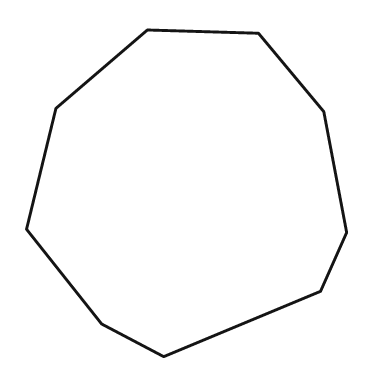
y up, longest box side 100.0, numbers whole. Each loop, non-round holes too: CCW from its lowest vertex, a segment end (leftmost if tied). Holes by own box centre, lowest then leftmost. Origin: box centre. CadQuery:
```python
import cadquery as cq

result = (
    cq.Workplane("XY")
    .moveTo(-7.0, -50.0)
    .lineTo(41.0, -30.0)
    .lineTo(49.0, -12.0)
    .lineTo(42.0, 25.0)
    .lineTo(22.0, 49.0)
    .lineTo(-12.0, 50.0)
    .lineTo(-40.0, 26.0)
    .lineTo(-49.0, -11.0)
    .lineTo(-26.0, -40.0)
    .close()
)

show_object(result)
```